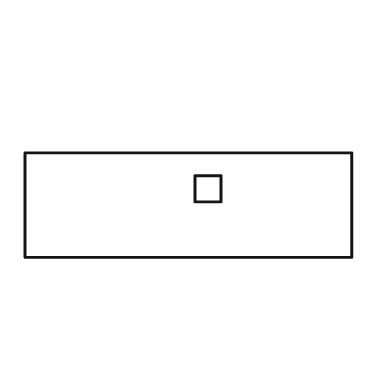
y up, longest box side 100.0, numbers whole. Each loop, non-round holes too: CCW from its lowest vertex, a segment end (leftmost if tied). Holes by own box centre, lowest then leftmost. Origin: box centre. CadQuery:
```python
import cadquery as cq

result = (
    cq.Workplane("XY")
    .moveTo(-50.0, -16.0)
    .lineTo(50.0, -16.0)
    .lineTo(50.0, 16.0)
    .lineTo(-50.0, 16.0)
    .close()
    .moveTo(2.0, 1.0)
    .lineTo(10.0, 1.0)
    .lineTo(10.0, 9.0)
    .lineTo(2.0, 9.0)
    .close()
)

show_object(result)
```